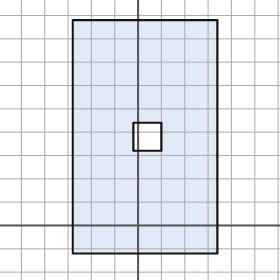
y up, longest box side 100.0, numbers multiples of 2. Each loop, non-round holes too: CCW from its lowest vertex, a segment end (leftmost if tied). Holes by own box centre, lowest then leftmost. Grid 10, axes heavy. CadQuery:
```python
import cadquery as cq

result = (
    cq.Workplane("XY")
    .moveTo(-28.0, -12.0)
    .lineTo(34.0, -12.0)
    .lineTo(34.0, 88.0)
    .lineTo(-28.0, 88.0)
    .close()
    .moveTo(-2.0, 32.0)
    .lineTo(10.0, 32.0)
    .lineTo(10.0, 44.0)
    .lineTo(-2.0, 44.0)
    .close()
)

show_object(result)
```